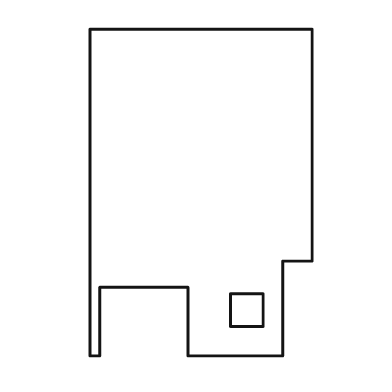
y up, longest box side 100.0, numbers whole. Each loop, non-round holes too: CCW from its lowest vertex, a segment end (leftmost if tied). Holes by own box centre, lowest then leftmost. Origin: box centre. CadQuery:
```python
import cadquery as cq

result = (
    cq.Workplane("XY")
    .moveTo(-34.0, -50.0)
    .lineTo(-31.0, -50.0)
    .lineTo(-31.0, -29.0)
    .lineTo(-4.0, -29.0)
    .lineTo(-4.0, -50.0)
    .lineTo(25.0, -50.0)
    .lineTo(25.0, -21.0)
    .lineTo(34.0, -21.0)
    .lineTo(34.0, 50.0)
    .lineTo(-34.0, 50.0)
    .close()
    .moveTo(9.0, -41.0)
    .lineTo(19.0, -41.0)
    .lineTo(19.0, -31.0)
    .lineTo(9.0, -31.0)
    .close()
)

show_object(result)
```